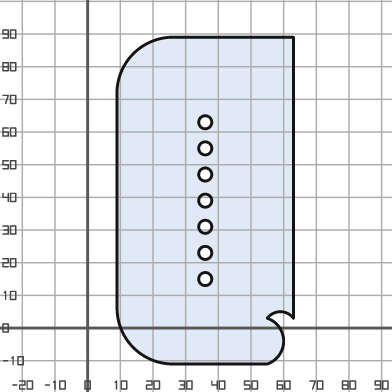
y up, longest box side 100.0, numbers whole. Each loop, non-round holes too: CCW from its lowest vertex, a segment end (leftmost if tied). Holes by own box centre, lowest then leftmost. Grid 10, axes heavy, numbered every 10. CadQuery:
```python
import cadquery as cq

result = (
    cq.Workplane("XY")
    .moveTo(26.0, -11.0)
    .lineTo(55.0, -11.0)
    .threePointArc((60.0, -4.0), (55.0, 3.0))
    .threePointArc((59.0, 5.0), (63.0, 3.0))
    .lineTo(63.0, 89.0)
    .lineTo(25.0, 89.0)
    .threePointArc((14.0, 84.0), (9.0, 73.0))
    .lineTo(9.0, 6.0)
    .threePointArc((14.0, -6.0), (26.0, -11.0))
    .close()
    .moveTo(36.0, 15.0)
    .circle(2.0)
    .moveTo(36.0, 23.0)
    .circle(2.0)
    .moveTo(36.0, 31.0)
    .circle(2.0)
    .moveTo(36.0, 39.0)
    .circle(2.0)
    .moveTo(36.0, 47.0)
    .circle(2.0)
    .moveTo(36.0, 55.0)
    .circle(2.0)
    .moveTo(36.0, 63.0)
    .circle(2.0)
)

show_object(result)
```